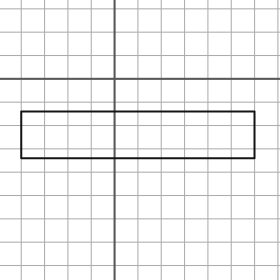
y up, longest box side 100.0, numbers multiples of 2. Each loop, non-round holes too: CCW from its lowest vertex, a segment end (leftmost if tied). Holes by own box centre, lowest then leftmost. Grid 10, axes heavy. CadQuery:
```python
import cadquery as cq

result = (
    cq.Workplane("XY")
    .moveTo(-40.0, -34.0)
    .lineTo(60.0, -34.0)
    .lineTo(60.0, -14.0)
    .lineTo(-40.0, -14.0)
    .close()
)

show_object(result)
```